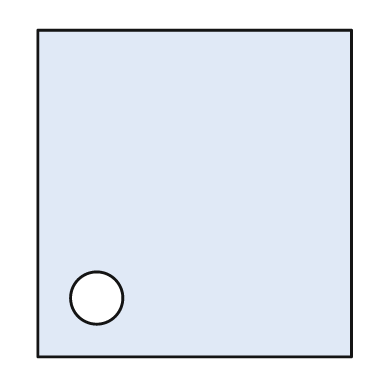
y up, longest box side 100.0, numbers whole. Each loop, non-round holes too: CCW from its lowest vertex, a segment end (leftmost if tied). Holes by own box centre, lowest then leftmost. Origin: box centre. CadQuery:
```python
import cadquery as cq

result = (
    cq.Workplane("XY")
    .moveTo(-48.0, -50.0)
    .lineTo(48.0, -50.0)
    .lineTo(48.0, 50.0)
    .lineTo(-48.0, 50.0)
    .close()
    .moveTo(-30.0, -32.0)
    .circle(8.0)
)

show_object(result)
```